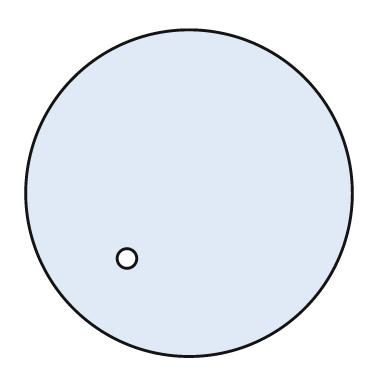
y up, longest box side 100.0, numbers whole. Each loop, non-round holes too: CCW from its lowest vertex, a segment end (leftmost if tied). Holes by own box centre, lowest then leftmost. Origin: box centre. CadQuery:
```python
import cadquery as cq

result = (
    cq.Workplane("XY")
    .moveTo(0.0, 0.0)
    .circle(50.0)
    .moveTo(-19.0, -20.0)
    .circle(3.0)
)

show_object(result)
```